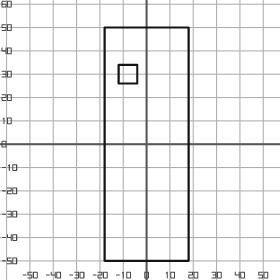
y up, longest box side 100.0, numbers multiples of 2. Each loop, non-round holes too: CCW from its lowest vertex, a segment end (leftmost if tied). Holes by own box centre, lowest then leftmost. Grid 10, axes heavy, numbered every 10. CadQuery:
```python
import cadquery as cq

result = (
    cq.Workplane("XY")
    .moveTo(-18.0, -50.0)
    .lineTo(18.0, -50.0)
    .lineTo(18.0, 50.0)
    .lineTo(-18.0, 50.0)
    .close()
    .moveTo(-12.0, 26.0)
    .lineTo(-4.0, 26.0)
    .lineTo(-4.0, 34.0)
    .lineTo(-12.0, 34.0)
    .close()
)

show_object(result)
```